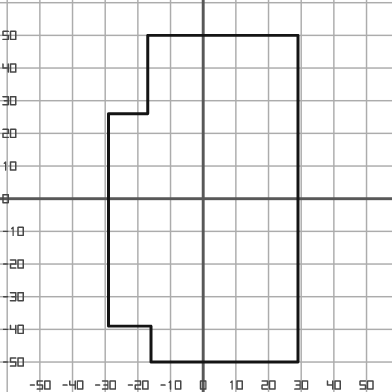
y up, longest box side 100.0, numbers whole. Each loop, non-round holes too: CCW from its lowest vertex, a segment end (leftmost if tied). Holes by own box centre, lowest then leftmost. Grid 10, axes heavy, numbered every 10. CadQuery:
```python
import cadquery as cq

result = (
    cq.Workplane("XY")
    .moveTo(-16.0, -50.0)
    .lineTo(29.0, -50.0)
    .lineTo(29.0, 50.0)
    .lineTo(-17.0, 50.0)
    .lineTo(-17.0, 26.0)
    .lineTo(-29.0, 26.0)
    .lineTo(-29.0, -39.0)
    .lineTo(-16.0, -39.0)
    .close()
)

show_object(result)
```